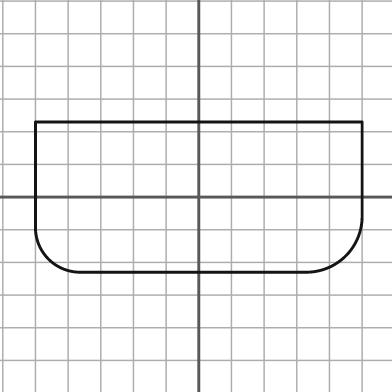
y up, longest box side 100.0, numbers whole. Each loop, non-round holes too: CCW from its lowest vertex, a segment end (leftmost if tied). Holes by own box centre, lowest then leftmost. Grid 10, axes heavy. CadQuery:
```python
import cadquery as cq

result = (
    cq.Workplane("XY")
    .moveTo(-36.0, -23.0)
    .lineTo(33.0, -23.0)
    .threePointArc((45.0, -18.0), (50.0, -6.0))
    .lineTo(50.0, 23.0)
    .lineTo(-50.0, 23.0)
    .lineTo(-50.0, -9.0)
    .threePointArc((-46.0, -19.0), (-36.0, -23.0))
    .close()
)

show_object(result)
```